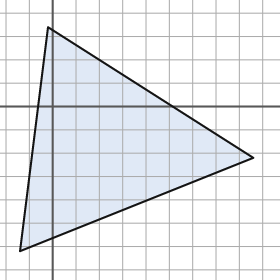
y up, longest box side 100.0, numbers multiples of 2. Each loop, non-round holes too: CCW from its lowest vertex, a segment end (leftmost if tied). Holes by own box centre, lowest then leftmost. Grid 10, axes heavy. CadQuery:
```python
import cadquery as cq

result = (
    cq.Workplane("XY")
    .moveTo(-14.0, -62.0)
    .lineTo(86.0, -22.0)
    .lineTo(-2.0, 34.0)
    .close()
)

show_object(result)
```